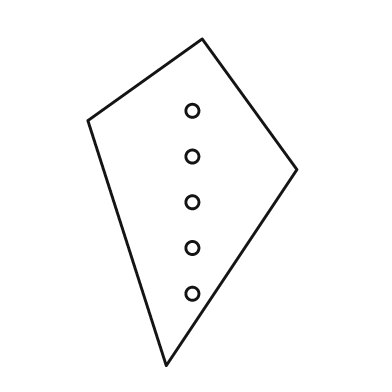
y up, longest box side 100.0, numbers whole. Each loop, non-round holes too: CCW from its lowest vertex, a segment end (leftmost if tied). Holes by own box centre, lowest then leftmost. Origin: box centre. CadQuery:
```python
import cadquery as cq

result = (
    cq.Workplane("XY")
    .moveTo(-8.0, -50.0)
    .lineTo(32.0, 10.0)
    .lineTo(3.0, 50.0)
    .lineTo(-32.0, 25.0)
    .close()
    .moveTo(0.0, -28.0)
    .circle(2.0)
    .moveTo(0.0, -14.0)
    .circle(2.0)
    .moveTo(0.0, 0.0)
    .circle(2.0)
    .moveTo(0.0, 14.0)
    .circle(2.0)
    .moveTo(0.0, 28.0)
    .circle(2.0)
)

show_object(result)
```